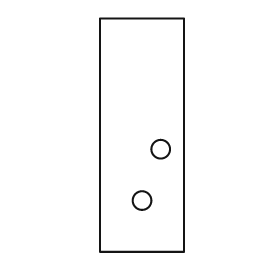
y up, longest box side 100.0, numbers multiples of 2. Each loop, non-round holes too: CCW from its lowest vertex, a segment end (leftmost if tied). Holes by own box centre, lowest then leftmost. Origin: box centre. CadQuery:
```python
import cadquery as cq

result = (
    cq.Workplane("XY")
    .moveTo(-18.0, -50.0)
    .lineTo(18.0, -50.0)
    .lineTo(18.0, 50.0)
    .lineTo(-18.0, 50.0)
    .close()
    .moveTo(0.0, -28.0)
    .circle(4.0)
    .moveTo(8.0, -6.0)
    .circle(4.0)
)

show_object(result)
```